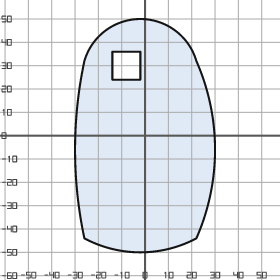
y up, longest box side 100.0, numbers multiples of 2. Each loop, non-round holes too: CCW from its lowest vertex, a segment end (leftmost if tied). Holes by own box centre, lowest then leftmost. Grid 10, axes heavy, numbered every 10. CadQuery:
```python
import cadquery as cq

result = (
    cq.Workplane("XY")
    .moveTo(-26.0, -44.0)
    .threePointArc((-2.0, -50.0), (22.0, -44.0))
    .threePointArc((30.0, -6.0), (22.0, 32.0))
    .threePointArc((-2.0, 50.0), (-26.0, 32.0))
    .threePointArc((-30.0, -6.0), (-26.0, -44.0))
    .close()
    .moveTo(-14.0, 24.0)
    .lineTo(-2.0, 24.0)
    .lineTo(-2.0, 36.0)
    .lineTo(-14.0, 36.0)
    .close()
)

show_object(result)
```